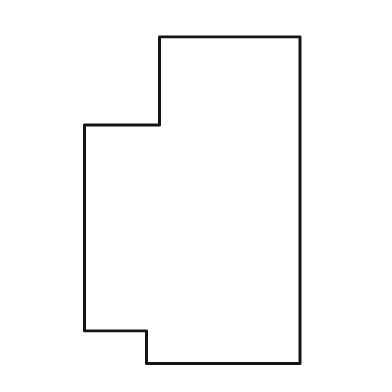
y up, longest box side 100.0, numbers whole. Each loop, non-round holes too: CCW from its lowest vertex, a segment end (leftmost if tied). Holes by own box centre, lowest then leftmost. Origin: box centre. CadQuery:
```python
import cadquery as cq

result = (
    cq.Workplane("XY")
    .moveTo(-14.0, -50.0)
    .lineTo(33.0, -50.0)
    .lineTo(33.0, 50.0)
    .lineTo(-10.0, 50.0)
    .lineTo(-10.0, 23.0)
    .lineTo(-33.0, 23.0)
    .lineTo(-33.0, -40.0)
    .lineTo(-14.0, -40.0)
    .close()
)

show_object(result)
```